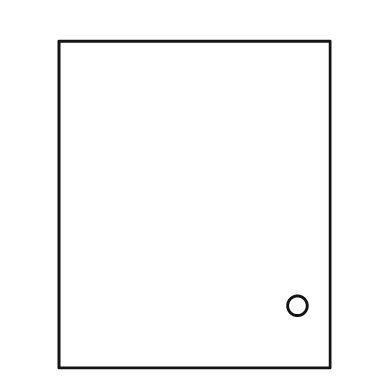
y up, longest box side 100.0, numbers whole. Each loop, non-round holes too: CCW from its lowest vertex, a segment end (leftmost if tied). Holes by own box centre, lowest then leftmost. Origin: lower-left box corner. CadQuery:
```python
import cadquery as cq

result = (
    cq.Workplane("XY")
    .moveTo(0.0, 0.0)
    .lineTo(83.0, 0.0)
    .lineTo(83.0, 100.0)
    .lineTo(0.0, 100.0)
    .close()
    .moveTo(73.0, 19.0)
    .circle(3.0)
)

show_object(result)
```